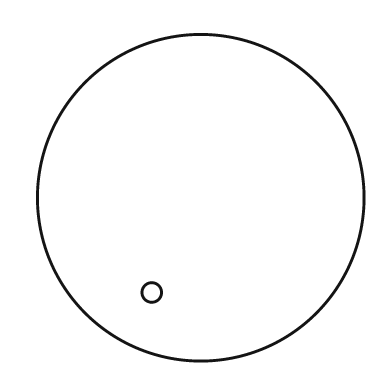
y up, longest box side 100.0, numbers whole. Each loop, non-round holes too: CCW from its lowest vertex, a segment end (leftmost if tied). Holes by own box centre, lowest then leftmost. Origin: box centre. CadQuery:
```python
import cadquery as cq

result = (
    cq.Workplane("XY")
    .moveTo(0.0, 0.0)
    .circle(50.0)
    .moveTo(-15.0, -29.0)
    .circle(3.0)
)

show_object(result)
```